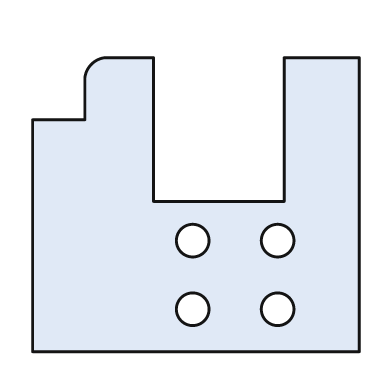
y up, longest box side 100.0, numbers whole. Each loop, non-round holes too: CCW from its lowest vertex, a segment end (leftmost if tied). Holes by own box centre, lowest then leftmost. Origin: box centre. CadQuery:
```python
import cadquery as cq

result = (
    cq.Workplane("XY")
    .moveTo(-50.0, -45.0)
    .lineTo(50.0, -45.0)
    .lineTo(50.0, 45.0)
    .lineTo(27.0, 45.0)
    .lineTo(27.0, 1.0)
    .lineTo(-13.0, 1.0)
    .lineTo(-13.0, 45.0)
    .lineTo(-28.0, 45.0)
    .threePointArc((-32.0, 43.0), (-34.0, 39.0))
    .lineTo(-34.0, 26.0)
    .lineTo(-50.0, 26.0)
    .close()
    .moveTo(-1.0, -32.0)
    .circle(5.0)
    .moveTo(25.0, -32.0)
    .circle(5.0)
    .moveTo(-1.0, -11.0)
    .circle(5.0)
    .moveTo(25.0, -11.0)
    .circle(5.0)
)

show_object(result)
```